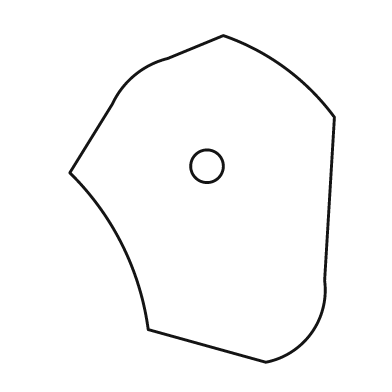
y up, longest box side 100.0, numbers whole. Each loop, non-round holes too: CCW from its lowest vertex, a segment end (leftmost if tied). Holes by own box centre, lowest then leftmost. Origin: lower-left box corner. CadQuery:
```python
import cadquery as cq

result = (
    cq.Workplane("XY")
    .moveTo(60.0, 0.0)
    .threePointArc((74.0, 9.0), (78.0, 25.0))
    .lineTo(81.0, 75.0)
    .threePointArc((66.0, 90.0), (47.0, 100.0))
    .lineTo(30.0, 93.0)
    .threePointArc((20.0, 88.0), (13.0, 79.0))
    .lineTo(0.0, 58.0)
    .threePointArc((16.0, 36.0), (24.0, 10.0))
    .close()
    .moveTo(42.0, 60.0)
    .circle(5.0)
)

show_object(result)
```